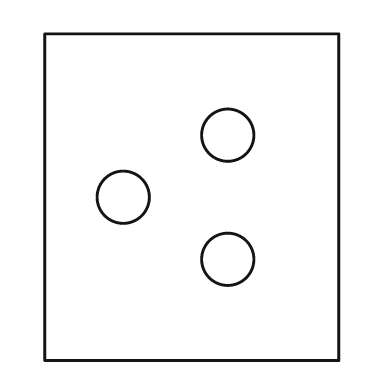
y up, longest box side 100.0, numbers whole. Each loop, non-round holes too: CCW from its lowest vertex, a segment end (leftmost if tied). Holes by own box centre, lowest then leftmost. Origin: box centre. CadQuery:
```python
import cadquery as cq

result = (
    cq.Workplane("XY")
    .moveTo(-45.0, -50.0)
    .lineTo(45.0, -50.0)
    .lineTo(45.0, 50.0)
    .lineTo(-45.0, 50.0)
    .close()
    .moveTo(11.0, -19.0)
    .circle(8.0)
    .moveTo(-21.0, 0.0)
    .circle(8.0)
    .moveTo(11.0, 19.0)
    .circle(8.0)
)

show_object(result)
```